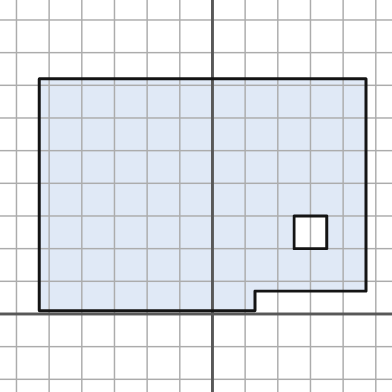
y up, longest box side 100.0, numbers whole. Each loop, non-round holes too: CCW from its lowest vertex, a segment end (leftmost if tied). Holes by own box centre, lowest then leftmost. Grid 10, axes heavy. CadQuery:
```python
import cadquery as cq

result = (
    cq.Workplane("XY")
    .moveTo(-53.0, 1.0)
    .lineTo(13.0, 1.0)
    .lineTo(13.0, 7.0)
    .lineTo(47.0, 7.0)
    .lineTo(47.0, 72.0)
    .lineTo(-53.0, 72.0)
    .close()
    .moveTo(25.0, 20.0)
    .lineTo(35.0, 20.0)
    .lineTo(35.0, 30.0)
    .lineTo(25.0, 30.0)
    .close()
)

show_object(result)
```